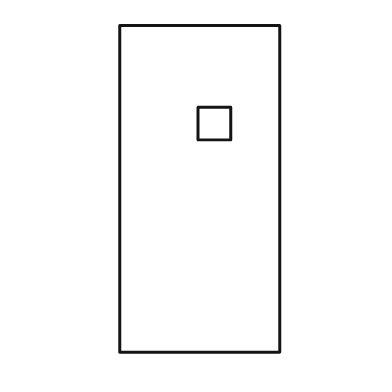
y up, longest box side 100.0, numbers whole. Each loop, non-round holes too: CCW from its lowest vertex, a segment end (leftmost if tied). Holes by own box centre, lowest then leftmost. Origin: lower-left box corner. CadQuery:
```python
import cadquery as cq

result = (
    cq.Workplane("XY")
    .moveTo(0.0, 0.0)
    .lineTo(49.0, 0.0)
    .lineTo(49.0, 100.0)
    .lineTo(0.0, 100.0)
    .close()
    .moveTo(24.0, 65.0)
    .lineTo(34.0, 65.0)
    .lineTo(34.0, 75.0)
    .lineTo(24.0, 75.0)
    .close()
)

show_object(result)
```